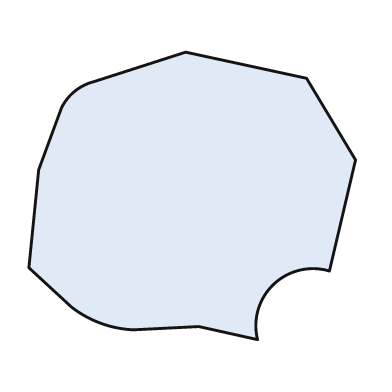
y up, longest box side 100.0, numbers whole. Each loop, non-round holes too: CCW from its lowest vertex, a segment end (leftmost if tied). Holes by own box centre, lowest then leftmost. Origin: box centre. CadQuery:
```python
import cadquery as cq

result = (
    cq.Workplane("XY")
    .moveTo(20.0, -44.0)
    .threePointArc((25.0, -27.0), (42.0, -23.0))
    .lineTo(50.0, 11.0)
    .lineTo(35.0, 36.0)
    .lineTo(-2.0, 44.0)
    .lineTo(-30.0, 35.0)
    .threePointArc((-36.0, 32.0), (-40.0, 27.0))
    .lineTo(-47.0, 8.0)
    .lineTo(-50.0, -22.0)
    .lineTo(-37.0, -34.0)
    .threePointArc((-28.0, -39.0), (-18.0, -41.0))
    .lineTo(2.0, -40.0)
    .close()
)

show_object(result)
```